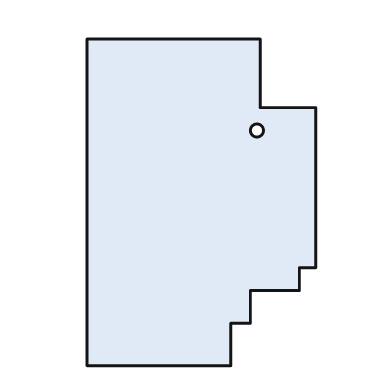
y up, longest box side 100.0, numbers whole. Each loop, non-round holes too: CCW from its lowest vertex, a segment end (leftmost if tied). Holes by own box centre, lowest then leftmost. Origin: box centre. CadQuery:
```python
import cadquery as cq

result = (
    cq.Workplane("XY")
    .moveTo(-35.0, -50.0)
    .lineTo(9.0, -50.0)
    .lineTo(9.0, -37.0)
    .lineTo(15.0, -37.0)
    .lineTo(15.0, -27.0)
    .lineTo(30.0, -27.0)
    .lineTo(30.0, -20.0)
    .lineTo(35.0, -20.0)
    .lineTo(35.0, 29.0)
    .lineTo(18.0, 29.0)
    .lineTo(18.0, 50.0)
    .lineTo(-35.0, 50.0)
    .close()
    .moveTo(17.0, 22.0)
    .circle(2.0)
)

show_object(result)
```